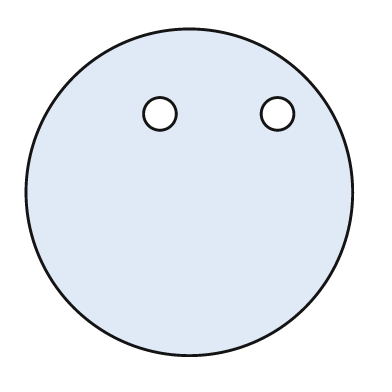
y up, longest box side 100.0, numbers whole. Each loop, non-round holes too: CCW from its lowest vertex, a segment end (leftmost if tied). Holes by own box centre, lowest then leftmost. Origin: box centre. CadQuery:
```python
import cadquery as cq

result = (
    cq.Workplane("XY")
    .moveTo(0.0, 0.0)
    .circle(50.0)
    .moveTo(-9.0, 24.0)
    .circle(5.0)
    .moveTo(27.0, 24.0)
    .circle(5.0)
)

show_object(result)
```